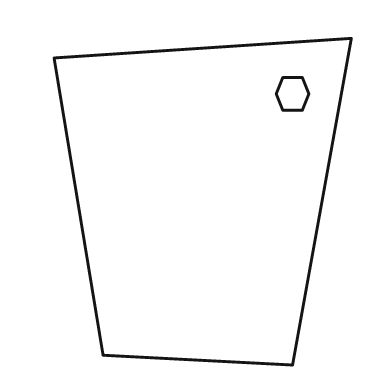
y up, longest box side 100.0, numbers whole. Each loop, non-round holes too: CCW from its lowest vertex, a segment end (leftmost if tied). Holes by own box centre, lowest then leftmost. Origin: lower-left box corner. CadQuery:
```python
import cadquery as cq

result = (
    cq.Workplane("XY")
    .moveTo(73.0, 0.0)
    .lineTo(91.0, 100.0)
    .lineTo(0.0, 94.0)
    .lineTo(15.0, 3.0)
    .close()
    .moveTo(70.0, 78.0)
    .lineTo(76.0, 78.0)
    .lineTo(78.0, 83.0)
    .lineTo(76.0, 88.0)
    .lineTo(70.0, 88.0)
    .lineTo(68.0, 83.0)
    .close()
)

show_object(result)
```